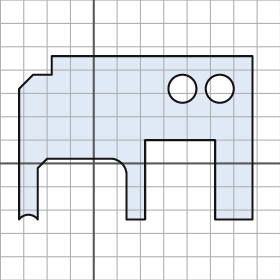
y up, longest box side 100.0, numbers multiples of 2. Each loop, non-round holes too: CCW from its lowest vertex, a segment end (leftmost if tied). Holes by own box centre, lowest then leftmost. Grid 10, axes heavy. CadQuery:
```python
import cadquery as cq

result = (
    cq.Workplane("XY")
    .moveTo(-32.0, -24.0)
    .threePointArc((-28.0, -22.0), (-24.0, -24.0))
    .lineTo(-24.0, -2.0)
    .lineTo(-20.0, 2.0)
    .lineTo(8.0, 2.0)
    .threePointArc((12.0, 0.0), (14.0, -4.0))
    .lineTo(14.0, -24.0)
    .lineTo(22.0, -24.0)
    .lineTo(22.0, 10.0)
    .lineTo(52.0, 10.0)
    .lineTo(52.0, -24.0)
    .lineTo(68.0, -24.0)
    .lineTo(68.0, 46.0)
    .lineTo(-18.0, 46.0)
    .lineTo(-18.0, 38.0)
    .lineTo(-26.0, 38.0)
    .lineTo(-32.0, 32.0)
    .close()
    .moveTo(38.0, 32.0)
    .circle(6.0)
    .moveTo(54.0, 32.0)
    .circle(6.0)
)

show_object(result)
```